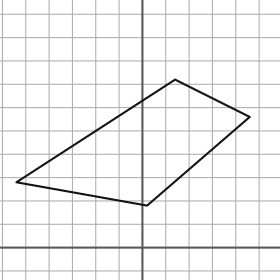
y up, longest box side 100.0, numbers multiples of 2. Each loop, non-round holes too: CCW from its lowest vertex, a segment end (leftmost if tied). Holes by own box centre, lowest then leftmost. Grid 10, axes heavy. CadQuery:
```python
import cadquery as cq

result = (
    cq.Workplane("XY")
    .moveTo(2.0, 18.0)
    .lineTo(46.0, 56.0)
    .lineTo(14.0, 72.0)
    .lineTo(-54.0, 28.0)
    .close()
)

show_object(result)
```